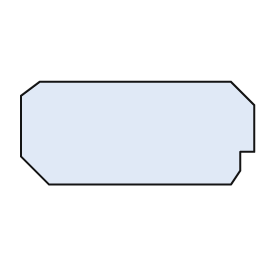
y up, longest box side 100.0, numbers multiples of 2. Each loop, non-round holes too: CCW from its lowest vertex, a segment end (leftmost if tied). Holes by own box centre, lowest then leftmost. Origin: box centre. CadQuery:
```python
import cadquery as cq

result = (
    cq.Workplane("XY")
    .moveTo(-38.0, -22.0)
    .lineTo(40.0, -22.0)
    .lineTo(44.0, -16.0)
    .lineTo(44.0, -8.0)
    .lineTo(50.0, -8.0)
    .lineTo(50.0, 12.0)
    .lineTo(40.0, 22.0)
    .lineTo(-42.0, 22.0)
    .lineTo(-50.0, 16.0)
    .lineTo(-50.0, -10.0)
    .close()
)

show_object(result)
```